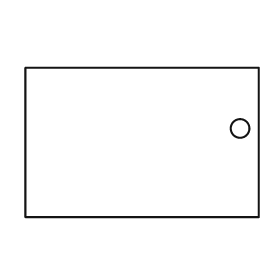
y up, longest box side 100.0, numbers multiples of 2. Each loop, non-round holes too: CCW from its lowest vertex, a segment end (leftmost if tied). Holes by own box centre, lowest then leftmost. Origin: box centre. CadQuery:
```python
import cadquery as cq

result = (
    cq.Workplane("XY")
    .moveTo(-50.0, -32.0)
    .lineTo(50.0, -32.0)
    .lineTo(50.0, 32.0)
    .lineTo(-50.0, 32.0)
    .close()
    .moveTo(42.0, 6.0)
    .circle(4.0)
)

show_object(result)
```